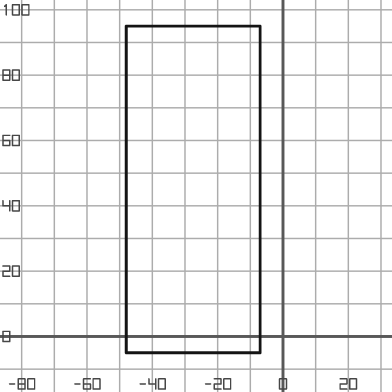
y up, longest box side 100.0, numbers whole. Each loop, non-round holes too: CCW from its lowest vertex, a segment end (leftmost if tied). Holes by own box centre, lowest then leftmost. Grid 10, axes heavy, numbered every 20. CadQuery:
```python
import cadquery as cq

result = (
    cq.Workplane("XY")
    .moveTo(-48.0, -5.0)
    .lineTo(-7.0, -5.0)
    .lineTo(-7.0, 95.0)
    .lineTo(-48.0, 95.0)
    .close()
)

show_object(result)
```